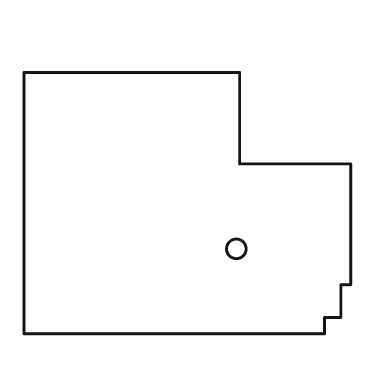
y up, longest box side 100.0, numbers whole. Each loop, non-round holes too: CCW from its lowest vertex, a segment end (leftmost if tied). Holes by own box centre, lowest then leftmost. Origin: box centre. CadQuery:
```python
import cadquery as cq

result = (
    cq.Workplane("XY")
    .moveTo(-50.0, -40.0)
    .lineTo(42.0, -40.0)
    .lineTo(42.0, -35.0)
    .lineTo(47.0, -35.0)
    .lineTo(47.0, -25.0)
    .lineTo(50.0, -25.0)
    .lineTo(50.0, 12.0)
    .lineTo(16.0, 12.0)
    .lineTo(16.0, 40.0)
    .lineTo(-50.0, 40.0)
    .close()
    .moveTo(15.0, -14.0)
    .circle(3.0)
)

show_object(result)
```